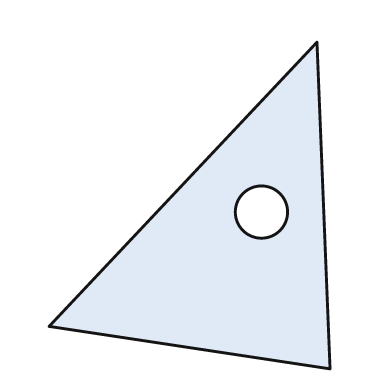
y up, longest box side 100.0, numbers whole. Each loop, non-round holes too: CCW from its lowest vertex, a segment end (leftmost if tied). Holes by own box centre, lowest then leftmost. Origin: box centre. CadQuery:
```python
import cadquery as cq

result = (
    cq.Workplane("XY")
    .moveTo(43.0, -50.0)
    .lineTo(39.0, 50.0)
    .lineTo(-43.0, -37.0)
    .close()
    .moveTo(22.0, -2.0)
    .circle(8.0)
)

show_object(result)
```